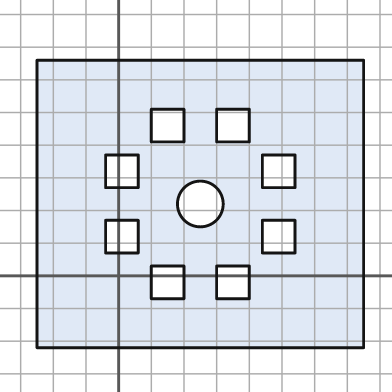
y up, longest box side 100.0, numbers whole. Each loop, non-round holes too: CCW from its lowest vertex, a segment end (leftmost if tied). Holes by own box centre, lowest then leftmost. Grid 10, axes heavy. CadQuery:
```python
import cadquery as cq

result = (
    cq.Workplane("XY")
    .moveTo(-25.0, -22.0)
    .lineTo(75.0, -22.0)
    .lineTo(75.0, 66.0)
    .lineTo(-25.0, 66.0)
    .close()
    .moveTo(10.0, -7.0)
    .lineTo(20.0, -7.0)
    .lineTo(20.0, 3.0)
    .lineTo(10.0, 3.0)
    .close()
    .moveTo(30.0, -7.0)
    .lineTo(40.0, -7.0)
    .lineTo(40.0, 3.0)
    .lineTo(30.0, 3.0)
    .close()
    .moveTo(-4.0, 7.0)
    .lineTo(6.0, 7.0)
    .lineTo(6.0, 17.0)
    .lineTo(-4.0, 17.0)
    .close()
    .moveTo(44.0, 7.0)
    .lineTo(54.0, 7.0)
    .lineTo(54.0, 17.0)
    .lineTo(44.0, 17.0)
    .close()
    .moveTo(25.0, 22.0)
    .circle(7.0)
    .moveTo(-4.0, 27.0)
    .lineTo(6.0, 27.0)
    .lineTo(6.0, 37.0)
    .lineTo(-4.0, 37.0)
    .close()
    .moveTo(44.0, 27.0)
    .lineTo(54.0, 27.0)
    .lineTo(54.0, 37.0)
    .lineTo(44.0, 37.0)
    .close()
    .moveTo(10.0, 41.0)
    .lineTo(20.0, 41.0)
    .lineTo(20.0, 51.0)
    .lineTo(10.0, 51.0)
    .close()
    .moveTo(30.0, 41.0)
    .lineTo(40.0, 41.0)
    .lineTo(40.0, 51.0)
    .lineTo(30.0, 51.0)
    .close()
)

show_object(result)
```